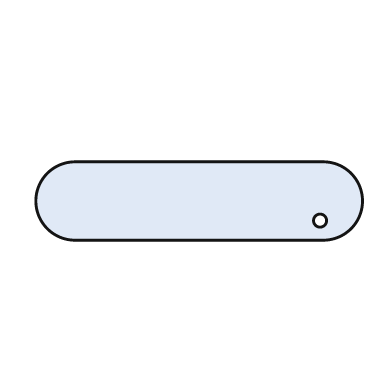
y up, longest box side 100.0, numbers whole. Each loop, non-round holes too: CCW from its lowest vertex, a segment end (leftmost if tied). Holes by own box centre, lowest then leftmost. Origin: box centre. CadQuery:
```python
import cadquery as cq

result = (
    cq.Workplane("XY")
    .moveTo(-38.0, -12.0)
    .lineTo(38.0, -12.0)
    .threePointArc((50.0, 0.0), (38.0, 12.0))
    .lineTo(-38.0, 12.0)
    .threePointArc((-50.0, 0.0), (-38.0, -12.0))
    .close()
    .moveTo(37.0, -6.0)
    .circle(2.0)
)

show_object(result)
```